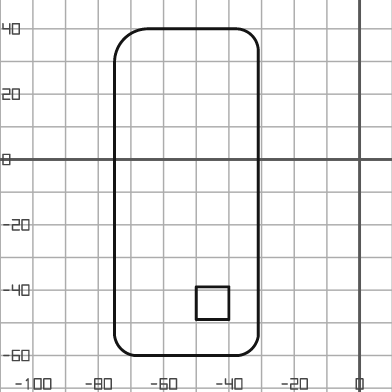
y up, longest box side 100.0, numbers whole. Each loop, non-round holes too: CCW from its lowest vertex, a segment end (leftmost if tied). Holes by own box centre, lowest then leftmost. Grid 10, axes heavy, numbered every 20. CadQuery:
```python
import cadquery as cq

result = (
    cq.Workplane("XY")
    .moveTo(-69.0, -60.0)
    .lineTo(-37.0, -60.0)
    .threePointArc((-33.0, -58.0), (-31.0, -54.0))
    .lineTo(-31.0, 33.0)
    .threePointArc((-33.0, 38.0), (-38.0, 40.0))
    .lineTo(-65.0, 40.0)
    .threePointArc((-72.0, 37.0), (-75.0, 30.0))
    .lineTo(-75.0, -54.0)
    .threePointArc((-73.0, -58.0), (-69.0, -60.0))
    .close()
    .moveTo(-50.0, -49.0)
    .lineTo(-40.0, -49.0)
    .lineTo(-40.0, -39.0)
    .lineTo(-50.0, -39.0)
    .close()
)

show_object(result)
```